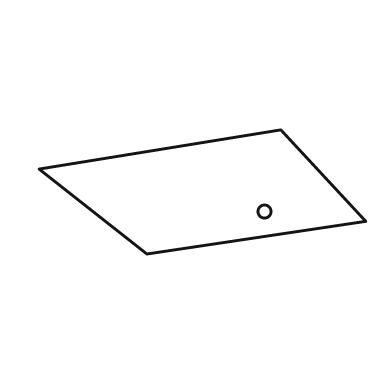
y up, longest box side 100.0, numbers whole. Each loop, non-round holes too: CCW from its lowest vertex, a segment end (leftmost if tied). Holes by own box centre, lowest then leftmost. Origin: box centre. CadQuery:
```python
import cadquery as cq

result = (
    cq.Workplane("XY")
    .moveTo(-17.0, -19.0)
    .lineTo(50.0, -9.0)
    .lineTo(24.0, 19.0)
    .lineTo(-50.0, 7.0)
    .close()
    .moveTo(19.0, -6.0)
    .circle(2.0)
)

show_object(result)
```